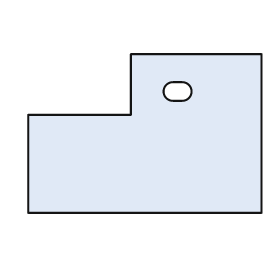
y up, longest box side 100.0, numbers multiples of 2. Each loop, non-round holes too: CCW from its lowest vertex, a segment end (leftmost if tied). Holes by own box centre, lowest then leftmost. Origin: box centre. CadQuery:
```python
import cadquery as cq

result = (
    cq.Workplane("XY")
    .moveTo(-50.0, -34.0)
    .lineTo(50.0, -34.0)
    .lineTo(50.0, 34.0)
    .lineTo(-6.0, 34.0)
    .lineTo(-6.0, 8.0)
    .lineTo(-50.0, 8.0)
    .close()
    .moveTo(12.0, 14.0)
    .lineTo(16.0, 14.0)
    .threePointArc((20.0, 18.0), (16.0, 22.0))
    .lineTo(12.0, 22.0)
    .threePointArc((8.0, 18.0), (12.0, 14.0))
    .close()
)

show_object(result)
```